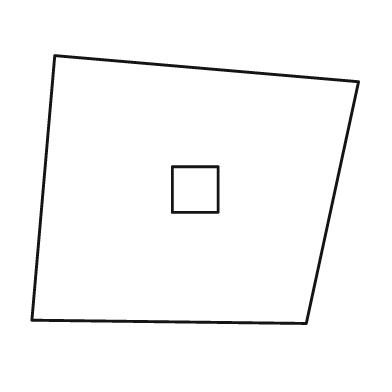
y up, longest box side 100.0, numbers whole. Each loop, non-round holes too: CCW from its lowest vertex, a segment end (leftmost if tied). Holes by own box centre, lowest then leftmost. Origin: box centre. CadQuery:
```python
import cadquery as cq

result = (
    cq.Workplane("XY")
    .moveTo(34.0, -41.0)
    .lineTo(50.0, 33.0)
    .lineTo(-43.0, 41.0)
    .lineTo(-50.0, -40.0)
    .close()
    .moveTo(-7.0, -7.0)
    .lineTo(7.0, -7.0)
    .lineTo(7.0, 7.0)
    .lineTo(-7.0, 7.0)
    .close()
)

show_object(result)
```